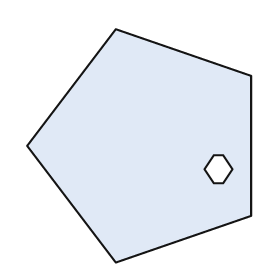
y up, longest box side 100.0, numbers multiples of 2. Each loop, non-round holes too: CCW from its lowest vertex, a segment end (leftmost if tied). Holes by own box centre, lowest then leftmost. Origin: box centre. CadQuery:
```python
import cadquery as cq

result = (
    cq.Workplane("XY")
    .moveTo(-10.0, -50.0)
    .lineTo(48.0, -30.0)
    .lineTo(48.0, 30.0)
    .lineTo(-10.0, 50.0)
    .lineTo(-48.0, 0.0)
    .close()
    .moveTo(32.0, -16.0)
    .lineTo(36.0, -16.0)
    .lineTo(40.0, -10.0)
    .lineTo(36.0, -4.0)
    .lineTo(32.0, -4.0)
    .lineTo(28.0, -10.0)
    .close()
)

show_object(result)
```